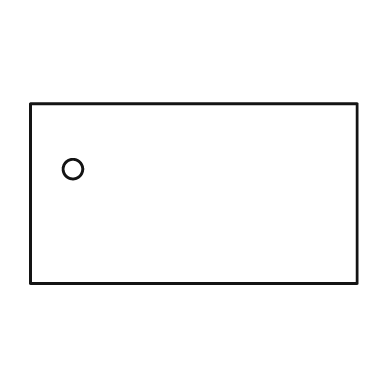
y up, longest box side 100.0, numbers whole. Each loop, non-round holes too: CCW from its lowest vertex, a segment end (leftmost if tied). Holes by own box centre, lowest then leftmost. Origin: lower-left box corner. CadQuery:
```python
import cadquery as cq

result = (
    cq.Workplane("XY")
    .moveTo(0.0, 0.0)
    .lineTo(100.0, 0.0)
    .lineTo(100.0, 55.0)
    .lineTo(0.0, 55.0)
    .close()
    .moveTo(13.0, 35.0)
    .circle(3.0)
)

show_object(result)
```